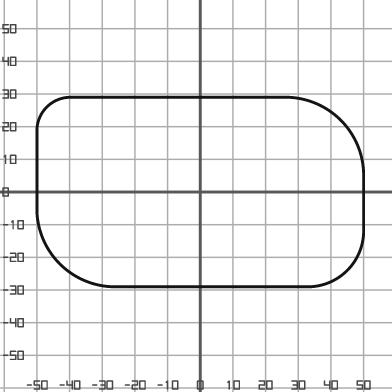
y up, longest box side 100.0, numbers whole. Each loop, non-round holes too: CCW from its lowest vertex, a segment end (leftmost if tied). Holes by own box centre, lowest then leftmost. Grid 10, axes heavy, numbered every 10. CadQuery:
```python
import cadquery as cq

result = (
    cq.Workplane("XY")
    .moveTo(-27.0, -29.0)
    .lineTo(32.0, -29.0)
    .threePointArc((45.0, -24.0), (50.0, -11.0))
    .lineTo(50.0, 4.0)
    .threePointArc((43.0, 22.0), (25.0, 29.0))
    .lineTo(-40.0, 29.0)
    .threePointArc((-47.0, 26.0), (-50.0, 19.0))
    .lineTo(-50.0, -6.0)
    .threePointArc((-43.0, -22.0), (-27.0, -29.0))
    .close()
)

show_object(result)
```